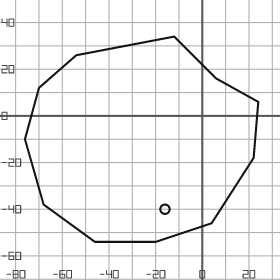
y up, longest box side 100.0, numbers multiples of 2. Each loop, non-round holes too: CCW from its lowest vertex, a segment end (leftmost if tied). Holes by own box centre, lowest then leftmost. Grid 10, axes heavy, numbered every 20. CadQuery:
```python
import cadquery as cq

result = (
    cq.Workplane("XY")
    .moveTo(-46.0, -54.0)
    .lineTo(-20.0, -54.0)
    .lineTo(4.0, -46.0)
    .lineTo(22.0, -18.0)
    .lineTo(24.0, 6.0)
    .lineTo(6.0, 16.0)
    .lineTo(-12.0, 34.0)
    .lineTo(-54.0, 26.0)
    .lineTo(-70.0, 12.0)
    .lineTo(-76.0, -10.0)
    .lineTo(-68.0, -38.0)
    .close()
    .moveTo(-16.0, -40.0)
    .circle(2.0)
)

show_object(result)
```